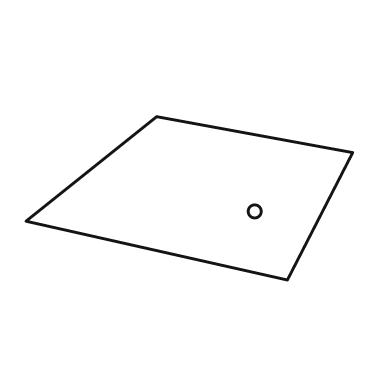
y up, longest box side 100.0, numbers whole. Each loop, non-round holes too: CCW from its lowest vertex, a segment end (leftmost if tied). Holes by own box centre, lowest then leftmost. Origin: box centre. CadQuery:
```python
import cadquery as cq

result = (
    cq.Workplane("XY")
    .moveTo(30.0, -25.0)
    .lineTo(50.0, 14.0)
    .lineTo(-10.0, 25.0)
    .lineTo(-50.0, -7.0)
    .close()
    .moveTo(20.0, -4.0)
    .circle(2.0)
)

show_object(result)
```